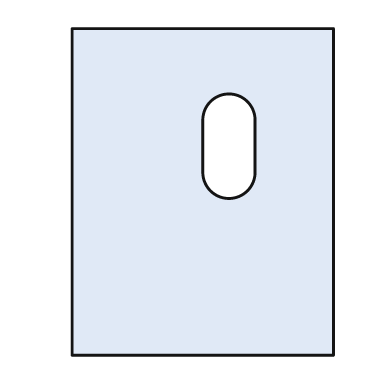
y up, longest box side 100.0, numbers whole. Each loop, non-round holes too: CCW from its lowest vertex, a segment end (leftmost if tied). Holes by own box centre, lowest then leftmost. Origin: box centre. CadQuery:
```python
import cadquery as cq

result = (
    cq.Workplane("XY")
    .moveTo(-40.0, -50.0)
    .lineTo(40.0, -50.0)
    .lineTo(40.0, 50.0)
    .lineTo(-40.0, 50.0)
    .close()
    .moveTo(0.0, 6.0)
    .threePointArc((8.0, -2.0), (16.0, 6.0))
    .lineTo(16.0, 22.0)
    .threePointArc((8.0, 30.0), (0.0, 22.0))
    .close()
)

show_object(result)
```